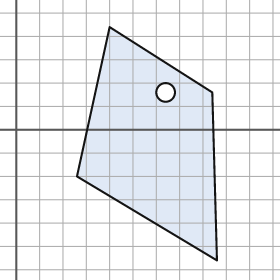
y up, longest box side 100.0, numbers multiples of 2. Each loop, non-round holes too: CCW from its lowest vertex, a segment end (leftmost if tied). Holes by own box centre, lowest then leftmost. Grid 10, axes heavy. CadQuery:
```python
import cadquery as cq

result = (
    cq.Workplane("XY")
    .moveTo(86.0, -56.0)
    .lineTo(84.0, 16.0)
    .lineTo(40.0, 44.0)
    .lineTo(26.0, -20.0)
    .close()
    .moveTo(64.0, 16.0)
    .circle(4.0)
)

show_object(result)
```